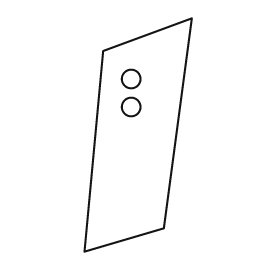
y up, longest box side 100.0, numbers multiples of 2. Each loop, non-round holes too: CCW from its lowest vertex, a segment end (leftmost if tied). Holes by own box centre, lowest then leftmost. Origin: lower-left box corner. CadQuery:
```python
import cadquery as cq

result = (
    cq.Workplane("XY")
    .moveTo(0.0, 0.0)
    .lineTo(34.0, 10.0)
    .lineTo(46.0, 100.0)
    .lineTo(8.0, 86.0)
    .close()
    .moveTo(20.0, 62.0)
    .circle(4.0)
    .moveTo(20.0, 74.0)
    .circle(4.0)
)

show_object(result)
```